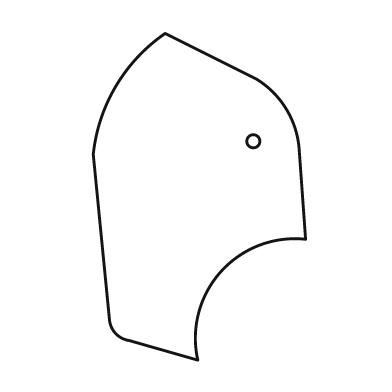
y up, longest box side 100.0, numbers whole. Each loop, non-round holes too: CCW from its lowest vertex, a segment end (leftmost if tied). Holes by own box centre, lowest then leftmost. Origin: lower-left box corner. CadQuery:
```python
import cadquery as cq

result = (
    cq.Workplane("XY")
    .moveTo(32.0, 0.0)
    .threePointArc((39.0, 27.0), (65.0, 37.0))
    .lineTo(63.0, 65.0)
    .threePointArc((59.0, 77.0), (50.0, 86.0))
    .lineTo(22.0, 100.0)
    .threePointArc((7.0, 84.0), (0.0, 63.0))
    .lineTo(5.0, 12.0)
    .threePointArc((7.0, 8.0), (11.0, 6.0))
    .close()
    .moveTo(49.0, 67.0)
    .circle(2.0)
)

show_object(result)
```